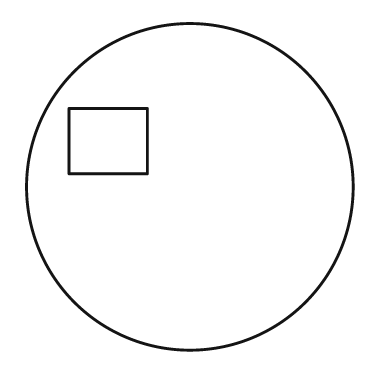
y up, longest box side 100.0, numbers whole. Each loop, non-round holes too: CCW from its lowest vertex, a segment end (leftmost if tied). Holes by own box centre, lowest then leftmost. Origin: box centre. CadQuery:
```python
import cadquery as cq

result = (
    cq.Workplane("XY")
    .moveTo(0.0, 0.0)
    .circle(50.0)
    .moveTo(-37.0, 4.0)
    .lineTo(-13.0, 4.0)
    .lineTo(-13.0, 24.0)
    .lineTo(-37.0, 24.0)
    .close()
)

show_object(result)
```